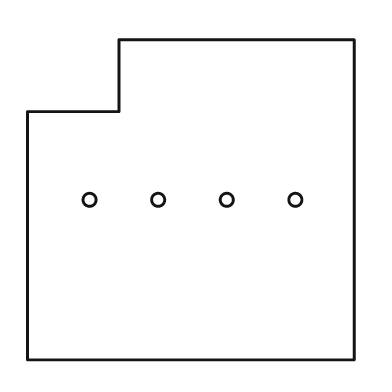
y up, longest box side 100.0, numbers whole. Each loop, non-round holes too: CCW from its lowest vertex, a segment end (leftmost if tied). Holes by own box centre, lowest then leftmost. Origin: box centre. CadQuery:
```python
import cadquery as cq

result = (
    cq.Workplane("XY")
    .moveTo(-50.0, -49.0)
    .lineTo(50.0, -49.0)
    .lineTo(50.0, 49.0)
    .lineTo(-22.0, 49.0)
    .lineTo(-22.0, 27.0)
    .lineTo(-50.0, 27.0)
    .close()
    .moveTo(-31.0, 0.0)
    .circle(2.0)
    .moveTo(-10.0, 0.0)
    .circle(2.0)
    .moveTo(11.0, 0.0)
    .circle(2.0)
    .moveTo(32.0, 0.0)
    .circle(2.0)
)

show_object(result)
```